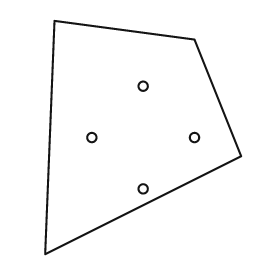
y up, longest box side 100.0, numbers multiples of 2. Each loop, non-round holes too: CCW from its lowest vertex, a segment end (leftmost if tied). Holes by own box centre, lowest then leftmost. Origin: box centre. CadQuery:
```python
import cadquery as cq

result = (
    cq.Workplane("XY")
    .moveTo(-42.0, -50.0)
    .lineTo(42.0, -8.0)
    .lineTo(22.0, 42.0)
    .lineTo(-38.0, 50.0)
    .close()
    .moveTo(0.0, -22.0)
    .circle(2.0)
    .moveTo(-22.0, 0.0)
    .circle(2.0)
    .moveTo(22.0, 0.0)
    .circle(2.0)
    .moveTo(0.0, 22.0)
    .circle(2.0)
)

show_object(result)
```